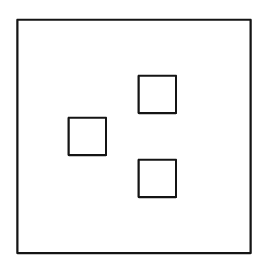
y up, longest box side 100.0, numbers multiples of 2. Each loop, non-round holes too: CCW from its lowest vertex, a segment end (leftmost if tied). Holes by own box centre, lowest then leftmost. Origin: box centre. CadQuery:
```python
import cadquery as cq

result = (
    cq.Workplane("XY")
    .moveTo(-50.0, -50.0)
    .lineTo(50.0, -50.0)
    .lineTo(50.0, 50.0)
    .lineTo(-50.0, 50.0)
    .close()
    .moveTo(2.0, -26.0)
    .lineTo(18.0, -26.0)
    .lineTo(18.0, -10.0)
    .lineTo(2.0, -10.0)
    .close()
    .moveTo(-28.0, -8.0)
    .lineTo(-12.0, -8.0)
    .lineTo(-12.0, 8.0)
    .lineTo(-28.0, 8.0)
    .close()
    .moveTo(2.0, 10.0)
    .lineTo(18.0, 10.0)
    .lineTo(18.0, 26.0)
    .lineTo(2.0, 26.0)
    .close()
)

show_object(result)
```